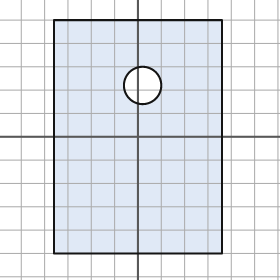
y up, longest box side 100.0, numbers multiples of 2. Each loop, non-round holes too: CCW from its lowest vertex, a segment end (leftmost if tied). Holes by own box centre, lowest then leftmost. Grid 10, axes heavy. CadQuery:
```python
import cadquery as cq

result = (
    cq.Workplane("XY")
    .moveTo(-36.0, -50.0)
    .lineTo(36.0, -50.0)
    .lineTo(36.0, 50.0)
    .lineTo(-36.0, 50.0)
    .close()
    .moveTo(2.0, 22.0)
    .circle(8.0)
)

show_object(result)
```